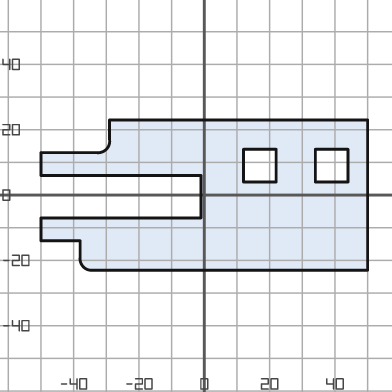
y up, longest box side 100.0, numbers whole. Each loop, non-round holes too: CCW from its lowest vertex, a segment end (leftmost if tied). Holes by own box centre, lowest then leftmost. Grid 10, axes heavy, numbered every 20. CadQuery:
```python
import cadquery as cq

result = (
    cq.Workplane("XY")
    .moveTo(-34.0, -23.0)
    .lineTo(50.0, -23.0)
    .lineTo(50.0, 23.0)
    .lineTo(-29.0, 23.0)
    .lineTo(-29.0, 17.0)
    .threePointArc((-30.0, 14.0), (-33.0, 13.0))
    .lineTo(-50.0, 13.0)
    .lineTo(-50.0, 6.0)
    .lineTo(-1.0, 6.0)
    .lineTo(-1.0, -7.0)
    .lineTo(-50.0, -7.0)
    .lineTo(-50.0, -14.0)
    .lineTo(-38.0, -14.0)
    .lineTo(-38.0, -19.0)
    .threePointArc((-37.0, -22.0), (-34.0, -23.0))
    .close()
    .moveTo(12.0, 4.0)
    .lineTo(22.0, 4.0)
    .lineTo(22.0, 14.0)
    .lineTo(12.0, 14.0)
    .close()
    .moveTo(34.0, 4.0)
    .lineTo(44.0, 4.0)
    .lineTo(44.0, 14.0)
    .lineTo(34.0, 14.0)
    .close()
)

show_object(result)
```